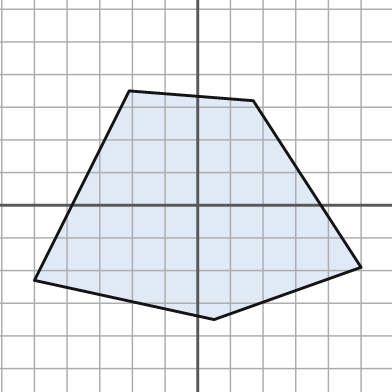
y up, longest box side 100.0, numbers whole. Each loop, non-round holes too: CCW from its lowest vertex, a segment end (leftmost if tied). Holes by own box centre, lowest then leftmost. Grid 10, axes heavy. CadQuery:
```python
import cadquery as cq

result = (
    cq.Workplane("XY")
    .moveTo(5.0, -35.0)
    .lineTo(50.0, -19.0)
    .lineTo(17.0, 32.0)
    .lineTo(-21.0, 35.0)
    .lineTo(-50.0, -23.0)
    .close()
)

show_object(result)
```